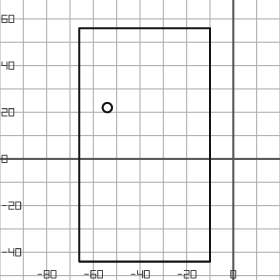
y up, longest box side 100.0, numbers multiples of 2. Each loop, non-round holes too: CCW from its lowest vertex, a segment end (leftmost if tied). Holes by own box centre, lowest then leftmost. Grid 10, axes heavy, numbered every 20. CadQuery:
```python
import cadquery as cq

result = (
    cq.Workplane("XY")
    .moveTo(-66.0, -44.0)
    .lineTo(-10.0, -44.0)
    .lineTo(-10.0, 56.0)
    .lineTo(-66.0, 56.0)
    .close()
    .moveTo(-54.0, 22.0)
    .circle(2.0)
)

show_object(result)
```